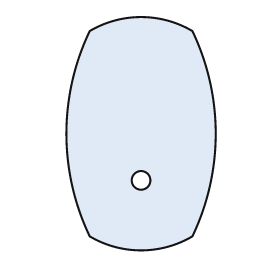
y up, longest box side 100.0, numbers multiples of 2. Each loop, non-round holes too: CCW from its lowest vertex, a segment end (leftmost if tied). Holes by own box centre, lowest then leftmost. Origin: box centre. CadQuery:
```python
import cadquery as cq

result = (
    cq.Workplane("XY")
    .moveTo(-22.0, -44.0)
    .threePointArc((0.0, -50.0), (22.0, -44.0))
    .threePointArc((32.0, 0.0), (22.0, 44.0))
    .threePointArc((0.0, 50.0), (-22.0, 44.0))
    .threePointArc((-32.0, 0.0), (-22.0, -44.0))
    .close()
    .moveTo(0.0, -20.0)
    .circle(4.0)
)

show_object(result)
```